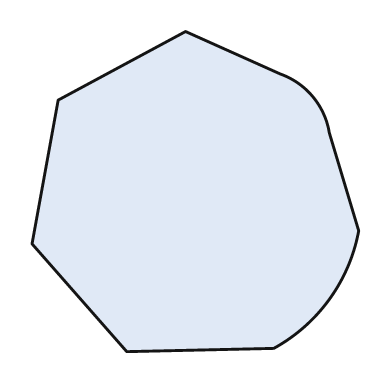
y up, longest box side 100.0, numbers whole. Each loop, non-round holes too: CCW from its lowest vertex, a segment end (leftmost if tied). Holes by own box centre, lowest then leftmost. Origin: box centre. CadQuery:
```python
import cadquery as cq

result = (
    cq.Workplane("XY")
    .moveTo(-21.0, -49.0)
    .lineTo(24.0, -48.0)
    .threePointArc((41.0, -33.0), (50.0, -12.0))
    .lineTo(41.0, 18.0)
    .threePointArc((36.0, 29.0), (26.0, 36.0))
    .lineTo(-3.0, 49.0)
    .lineTo(-42.0, 28.0)
    .lineTo(-50.0, -16.0)
    .close()
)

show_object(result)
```